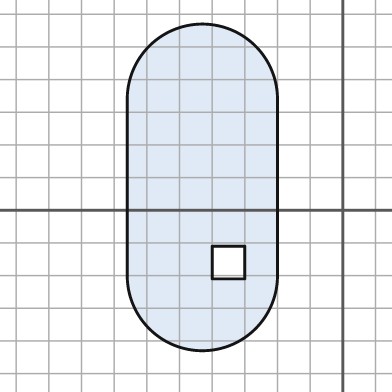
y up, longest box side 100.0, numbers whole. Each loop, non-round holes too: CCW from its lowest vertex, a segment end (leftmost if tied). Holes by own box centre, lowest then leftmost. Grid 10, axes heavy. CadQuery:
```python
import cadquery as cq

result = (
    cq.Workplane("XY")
    .moveTo(-66.0, -20.0)
    .threePointArc((-43.0, -43.0), (-20.0, -20.0))
    .lineTo(-20.0, 34.0)
    .threePointArc((-43.0, 57.0), (-66.0, 34.0))
    .close()
    .moveTo(-40.0, -21.0)
    .lineTo(-30.0, -21.0)
    .lineTo(-30.0, -11.0)
    .lineTo(-40.0, -11.0)
    .close()
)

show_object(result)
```